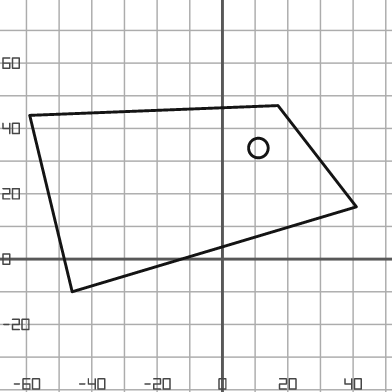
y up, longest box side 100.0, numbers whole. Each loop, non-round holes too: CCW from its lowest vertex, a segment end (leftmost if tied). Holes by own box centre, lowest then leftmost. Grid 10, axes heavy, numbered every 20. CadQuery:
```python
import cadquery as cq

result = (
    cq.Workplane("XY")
    .moveTo(-46.0, -10.0)
    .lineTo(41.0, 16.0)
    .lineTo(17.0, 47.0)
    .lineTo(-59.0, 44.0)
    .close()
    .moveTo(11.0, 34.0)
    .circle(3.0)
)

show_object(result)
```